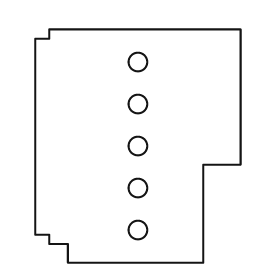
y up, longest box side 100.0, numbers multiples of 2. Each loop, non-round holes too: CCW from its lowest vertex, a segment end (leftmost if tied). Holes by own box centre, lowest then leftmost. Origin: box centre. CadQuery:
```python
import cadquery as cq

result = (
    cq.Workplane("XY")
    .moveTo(-30.0, -50.0)
    .lineTo(28.0, -50.0)
    .lineTo(28.0, -8.0)
    .lineTo(44.0, -8.0)
    .lineTo(44.0, 50.0)
    .lineTo(-38.0, 50.0)
    .lineTo(-38.0, 46.0)
    .lineTo(-44.0, 46.0)
    .lineTo(-44.0, -38.0)
    .lineTo(-38.0, -38.0)
    .lineTo(-38.0, -42.0)
    .lineTo(-30.0, -42.0)
    .close()
    .moveTo(0.0, -36.0)
    .circle(4.0)
    .moveTo(0.0, -18.0)
    .circle(4.0)
    .moveTo(0.0, 0.0)
    .circle(4.0)
    .moveTo(0.0, 18.0)
    .circle(4.0)
    .moveTo(0.0, 36.0)
    .circle(4.0)
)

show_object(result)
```